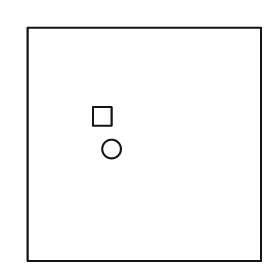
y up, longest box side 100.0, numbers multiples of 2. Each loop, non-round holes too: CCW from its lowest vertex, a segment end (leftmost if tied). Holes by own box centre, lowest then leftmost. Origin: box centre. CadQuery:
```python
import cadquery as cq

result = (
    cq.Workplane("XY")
    .moveTo(-50.0, -50.0)
    .lineTo(50.0, -50.0)
    .lineTo(50.0, 50.0)
    .lineTo(-50.0, 50.0)
    .close()
    .moveTo(-14.0, -2.0)
    .circle(4.0)
    .moveTo(-22.0, 8.0)
    .lineTo(-14.0, 8.0)
    .lineTo(-14.0, 16.0)
    .lineTo(-22.0, 16.0)
    .close()
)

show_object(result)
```